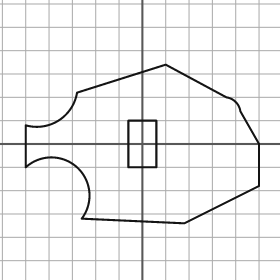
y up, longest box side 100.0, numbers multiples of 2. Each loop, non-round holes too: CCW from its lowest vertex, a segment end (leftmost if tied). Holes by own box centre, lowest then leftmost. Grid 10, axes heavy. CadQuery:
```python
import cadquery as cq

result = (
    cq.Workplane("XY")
    .moveTo(18.0, -34.0)
    .lineTo(50.0, -18.0)
    .lineTo(50.0, 0.0)
    .lineTo(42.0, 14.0)
    .threePointArc((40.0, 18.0), (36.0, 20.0))
    .lineTo(10.0, 34.0)
    .lineTo(-28.0, 22.0)
    .threePointArc((-36.0, 10.0), (-50.0, 8.0))
    .lineTo(-50.0, -10.0)
    .threePointArc((-28.0, -10.0), (-26.0, -32.0))
    .close()
    .moveTo(-6.0, -10.0)
    .lineTo(6.0, -10.0)
    .lineTo(6.0, 10.0)
    .lineTo(-6.0, 10.0)
    .close()
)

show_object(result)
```